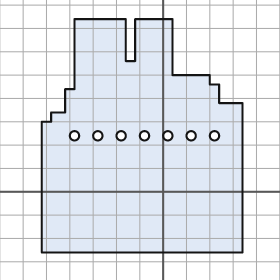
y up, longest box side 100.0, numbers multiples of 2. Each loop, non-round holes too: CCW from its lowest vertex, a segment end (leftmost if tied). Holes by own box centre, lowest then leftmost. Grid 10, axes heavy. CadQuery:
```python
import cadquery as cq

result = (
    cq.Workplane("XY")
    .moveTo(-52.0, -26.0)
    .lineTo(34.0, -26.0)
    .lineTo(34.0, 38.0)
    .lineTo(24.0, 38.0)
    .lineTo(24.0, 46.0)
    .lineTo(20.0, 46.0)
    .lineTo(20.0, 50.0)
    .lineTo(4.0, 50.0)
    .lineTo(4.0, 74.0)
    .lineTo(-12.0, 74.0)
    .lineTo(-12.0, 56.0)
    .lineTo(-16.0, 56.0)
    .lineTo(-16.0, 74.0)
    .lineTo(-38.0, 74.0)
    .lineTo(-38.0, 44.0)
    .lineTo(-42.0, 44.0)
    .lineTo(-42.0, 34.0)
    .lineTo(-48.0, 34.0)
    .lineTo(-48.0, 30.0)
    .lineTo(-52.0, 30.0)
    .close()
    .moveTo(-38.0, 24.0)
    .circle(2.0)
    .moveTo(-28.0, 24.0)
    .circle(2.0)
    .moveTo(-18.0, 24.0)
    .circle(2.0)
    .moveTo(-8.0, 24.0)
    .circle(2.0)
    .moveTo(2.0, 24.0)
    .circle(2.0)
    .moveTo(12.0, 24.0)
    .circle(2.0)
    .moveTo(22.0, 24.0)
    .circle(2.0)
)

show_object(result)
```